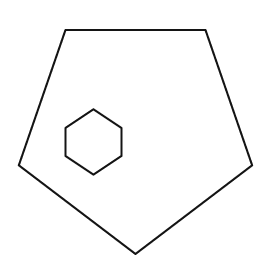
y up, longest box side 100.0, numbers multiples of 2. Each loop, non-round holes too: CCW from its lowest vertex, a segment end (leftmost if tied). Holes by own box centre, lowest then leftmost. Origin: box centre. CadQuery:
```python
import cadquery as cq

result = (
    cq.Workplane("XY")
    .moveTo(0.0, -48.0)
    .lineTo(50.0, -10.0)
    .lineTo(30.0, 48.0)
    .lineTo(-30.0, 48.0)
    .lineTo(-50.0, -10.0)
    .close()
    .moveTo(-18.0, -14.0)
    .lineTo(-6.0, -6.0)
    .lineTo(-6.0, 6.0)
    .lineTo(-18.0, 14.0)
    .lineTo(-30.0, 6.0)
    .lineTo(-30.0, -6.0)
    .close()
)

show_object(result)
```